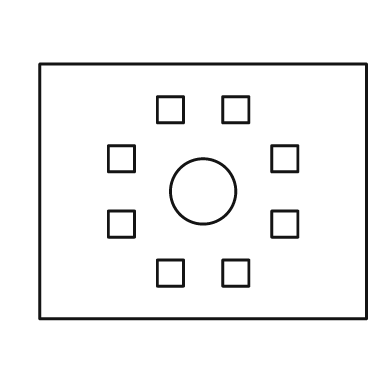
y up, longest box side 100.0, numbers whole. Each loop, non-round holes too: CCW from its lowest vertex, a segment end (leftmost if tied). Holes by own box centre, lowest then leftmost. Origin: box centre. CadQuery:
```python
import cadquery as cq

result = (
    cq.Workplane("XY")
    .moveTo(-50.0, -39.0)
    .lineTo(50.0, -39.0)
    .lineTo(50.0, 39.0)
    .lineTo(-50.0, 39.0)
    .close()
    .moveTo(-14.0, -29.0)
    .lineTo(-6.0, -29.0)
    .lineTo(-6.0, -21.0)
    .lineTo(-14.0, -21.0)
    .close()
    .moveTo(6.0, -29.0)
    .lineTo(14.0, -29.0)
    .lineTo(14.0, -21.0)
    .lineTo(6.0, -21.0)
    .close()
    .moveTo(-29.0, -14.0)
    .lineTo(-21.0, -14.0)
    .lineTo(-21.0, -6.0)
    .lineTo(-29.0, -6.0)
    .close()
    .moveTo(21.0, -14.0)
    .lineTo(29.0, -14.0)
    .lineTo(29.0, -6.0)
    .lineTo(21.0, -6.0)
    .close()
    .moveTo(0.0, 0.0)
    .circle(10.0)
    .moveTo(-29.0, 6.0)
    .lineTo(-21.0, 6.0)
    .lineTo(-21.0, 14.0)
    .lineTo(-29.0, 14.0)
    .close()
    .moveTo(21.0, 6.0)
    .lineTo(29.0, 6.0)
    .lineTo(29.0, 14.0)
    .lineTo(21.0, 14.0)
    .close()
    .moveTo(-14.0, 21.0)
    .lineTo(-6.0, 21.0)
    .lineTo(-6.0, 29.0)
    .lineTo(-14.0, 29.0)
    .close()
    .moveTo(6.0, 21.0)
    .lineTo(14.0, 21.0)
    .lineTo(14.0, 29.0)
    .lineTo(6.0, 29.0)
    .close()
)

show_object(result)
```